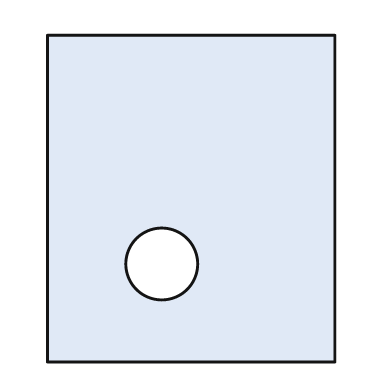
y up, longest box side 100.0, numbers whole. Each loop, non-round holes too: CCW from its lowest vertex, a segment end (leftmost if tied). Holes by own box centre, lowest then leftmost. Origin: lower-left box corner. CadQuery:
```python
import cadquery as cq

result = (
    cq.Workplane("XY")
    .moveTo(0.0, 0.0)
    .lineTo(88.0, 0.0)
    .lineTo(88.0, 100.0)
    .lineTo(0.0, 100.0)
    .close()
    .moveTo(35.0, 30.0)
    .circle(11.0)
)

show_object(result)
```